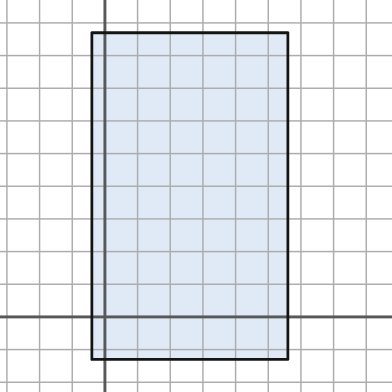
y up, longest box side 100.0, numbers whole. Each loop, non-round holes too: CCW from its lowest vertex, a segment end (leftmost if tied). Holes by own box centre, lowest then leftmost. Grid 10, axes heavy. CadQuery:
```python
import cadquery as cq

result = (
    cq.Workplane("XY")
    .moveTo(-4.0, -13.0)
    .lineTo(56.0, -13.0)
    .lineTo(56.0, 87.0)
    .lineTo(-4.0, 87.0)
    .close()
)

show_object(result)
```